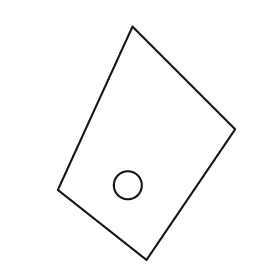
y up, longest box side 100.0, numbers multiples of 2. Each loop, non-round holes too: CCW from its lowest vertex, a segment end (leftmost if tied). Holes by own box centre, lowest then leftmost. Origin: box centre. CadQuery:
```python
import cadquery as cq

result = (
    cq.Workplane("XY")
    .moveTo(0.0, -50.0)
    .lineTo(38.0, 6.0)
    .lineTo(-6.0, 50.0)
    .lineTo(-38.0, -20.0)
    .close()
    .moveTo(-8.0, -18.0)
    .circle(6.0)
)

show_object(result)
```